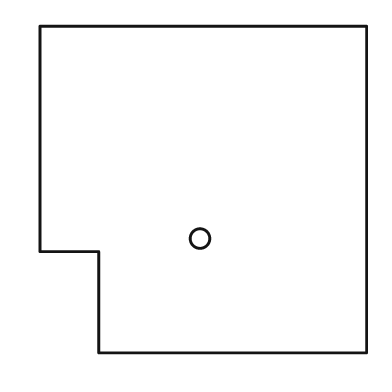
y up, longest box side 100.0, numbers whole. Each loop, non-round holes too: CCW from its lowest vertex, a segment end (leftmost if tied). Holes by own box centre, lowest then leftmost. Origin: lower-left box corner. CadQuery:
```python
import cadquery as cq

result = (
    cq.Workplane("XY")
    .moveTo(18.0, 0.0)
    .lineTo(100.0, 0.0)
    .lineTo(100.0, 100.0)
    .lineTo(0.0, 100.0)
    .lineTo(0.0, 31.0)
    .lineTo(18.0, 31.0)
    .close()
    .moveTo(49.0, 35.0)
    .circle(3.0)
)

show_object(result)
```